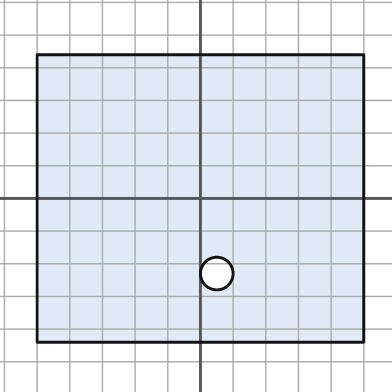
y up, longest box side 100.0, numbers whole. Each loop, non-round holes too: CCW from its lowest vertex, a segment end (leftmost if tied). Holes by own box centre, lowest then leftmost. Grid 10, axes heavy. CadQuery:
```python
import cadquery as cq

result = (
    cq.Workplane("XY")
    .moveTo(-50.0, -44.0)
    .lineTo(50.0, -44.0)
    .lineTo(50.0, 44.0)
    .lineTo(-50.0, 44.0)
    .close()
    .moveTo(5.0, -23.0)
    .circle(5.0)
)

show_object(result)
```